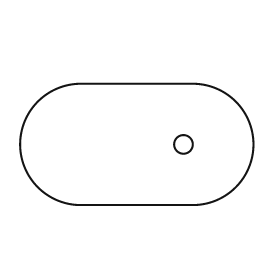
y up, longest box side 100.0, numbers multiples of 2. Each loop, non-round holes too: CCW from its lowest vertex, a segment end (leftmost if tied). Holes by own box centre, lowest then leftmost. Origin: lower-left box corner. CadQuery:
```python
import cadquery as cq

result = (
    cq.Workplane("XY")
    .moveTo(26.0, 0.0)
    .lineTo(74.0, 0.0)
    .threePointArc((100.0, 26.0), (74.0, 52.0))
    .lineTo(26.0, 52.0)
    .threePointArc((0.0, 26.0), (26.0, 0.0))
    .close()
    .moveTo(70.0, 26.0)
    .circle(4.0)
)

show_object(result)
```